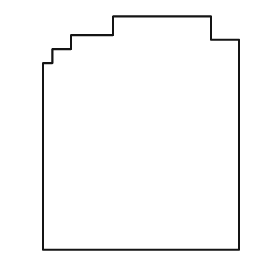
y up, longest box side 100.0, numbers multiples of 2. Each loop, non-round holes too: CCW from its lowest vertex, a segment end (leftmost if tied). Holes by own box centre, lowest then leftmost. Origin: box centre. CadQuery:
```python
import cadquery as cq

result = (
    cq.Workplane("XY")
    .moveTo(-42.0, -50.0)
    .lineTo(42.0, -50.0)
    .lineTo(42.0, 40.0)
    .lineTo(30.0, 40.0)
    .lineTo(30.0, 50.0)
    .lineTo(-12.0, 50.0)
    .lineTo(-12.0, 42.0)
    .lineTo(-30.0, 42.0)
    .lineTo(-30.0, 36.0)
    .lineTo(-38.0, 36.0)
    .lineTo(-38.0, 30.0)
    .lineTo(-42.0, 30.0)
    .close()
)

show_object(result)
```